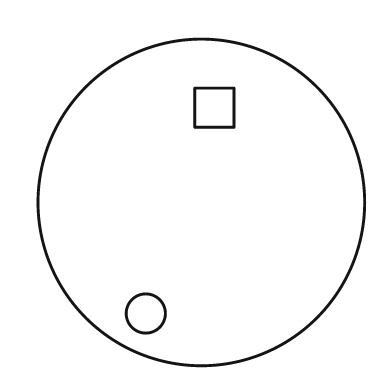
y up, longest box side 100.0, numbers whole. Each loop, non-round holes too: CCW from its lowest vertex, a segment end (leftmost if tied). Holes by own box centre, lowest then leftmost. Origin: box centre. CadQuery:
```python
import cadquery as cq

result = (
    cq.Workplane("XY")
    .moveTo(0.0, 0.0)
    .circle(50.0)
    .moveTo(-17.0, -34.0)
    .circle(6.0)
    .moveTo(-2.0, 23.0)
    .lineTo(10.0, 23.0)
    .lineTo(10.0, 35.0)
    .lineTo(-2.0, 35.0)
    .close()
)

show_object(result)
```